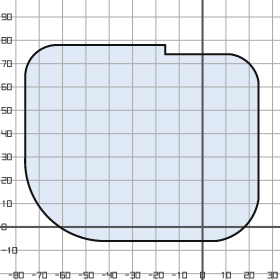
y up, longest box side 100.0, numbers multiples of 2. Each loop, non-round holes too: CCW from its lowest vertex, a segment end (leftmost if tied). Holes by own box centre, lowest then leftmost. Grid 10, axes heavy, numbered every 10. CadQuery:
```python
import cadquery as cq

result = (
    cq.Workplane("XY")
    .moveTo(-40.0, -6.0)
    .lineTo(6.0, -6.0)
    .threePointArc((18.0, 0.0), (24.0, 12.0))
    .lineTo(24.0, 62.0)
    .threePointArc((20.0, 70.0), (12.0, 74.0))
    .lineTo(-16.0, 74.0)
    .lineTo(-16.0, 78.0)
    .lineTo(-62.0, 78.0)
    .threePointArc((-72.0, 74.0), (-76.0, 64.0))
    .lineTo(-76.0, 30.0)
    .threePointArc((-66.0, 4.0), (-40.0, -6.0))
    .close()
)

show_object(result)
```